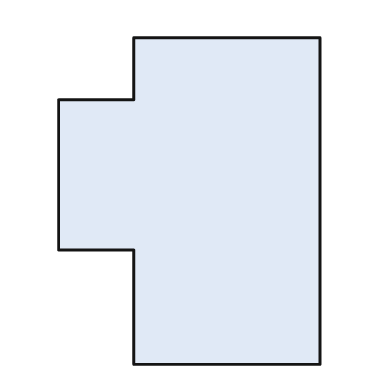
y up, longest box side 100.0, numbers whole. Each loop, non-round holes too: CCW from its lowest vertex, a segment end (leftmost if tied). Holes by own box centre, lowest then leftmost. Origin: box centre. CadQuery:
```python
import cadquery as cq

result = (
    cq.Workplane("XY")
    .moveTo(-17.0, -50.0)
    .lineTo(40.0, -50.0)
    .lineTo(40.0, 50.0)
    .lineTo(-17.0, 50.0)
    .lineTo(-17.0, 31.0)
    .lineTo(-40.0, 31.0)
    .lineTo(-40.0, -15.0)
    .lineTo(-17.0, -15.0)
    .close()
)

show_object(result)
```